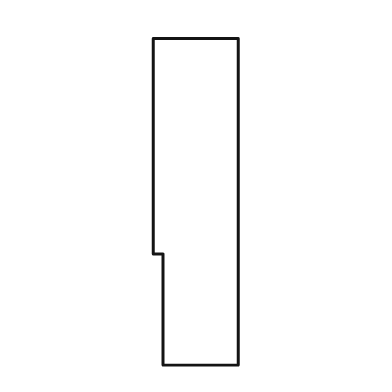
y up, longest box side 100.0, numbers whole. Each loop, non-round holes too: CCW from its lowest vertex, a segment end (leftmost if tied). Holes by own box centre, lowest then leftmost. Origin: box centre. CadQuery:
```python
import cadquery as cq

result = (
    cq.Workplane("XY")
    .moveTo(-10.0, -50.0)
    .lineTo(13.0, -50.0)
    .lineTo(13.0, 50.0)
    .lineTo(-13.0, 50.0)
    .lineTo(-13.0, -16.0)
    .lineTo(-10.0, -16.0)
    .close()
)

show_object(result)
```